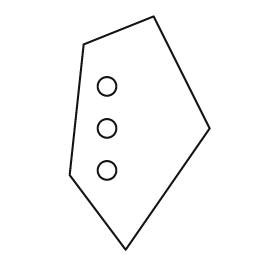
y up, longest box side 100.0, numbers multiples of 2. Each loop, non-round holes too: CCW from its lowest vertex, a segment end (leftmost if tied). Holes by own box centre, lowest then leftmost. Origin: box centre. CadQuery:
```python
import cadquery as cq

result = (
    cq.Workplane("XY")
    .moveTo(-6.0, -50.0)
    .lineTo(30.0, 2.0)
    .lineTo(6.0, 50.0)
    .lineTo(-24.0, 38.0)
    .lineTo(-30.0, -18.0)
    .close()
    .moveTo(-14.0, -16.0)
    .circle(4.0)
    .moveTo(-14.0, 2.0)
    .circle(4.0)
    .moveTo(-14.0, 20.0)
    .circle(4.0)
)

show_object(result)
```